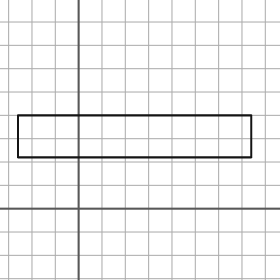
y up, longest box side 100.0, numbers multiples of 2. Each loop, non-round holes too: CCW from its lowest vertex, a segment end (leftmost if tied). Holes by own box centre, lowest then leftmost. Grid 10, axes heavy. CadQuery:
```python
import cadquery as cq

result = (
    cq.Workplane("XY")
    .moveTo(-26.0, 22.0)
    .lineTo(74.0, 22.0)
    .lineTo(74.0, 40.0)
    .lineTo(-26.0, 40.0)
    .close()
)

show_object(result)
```